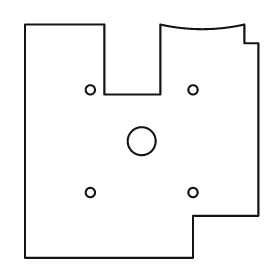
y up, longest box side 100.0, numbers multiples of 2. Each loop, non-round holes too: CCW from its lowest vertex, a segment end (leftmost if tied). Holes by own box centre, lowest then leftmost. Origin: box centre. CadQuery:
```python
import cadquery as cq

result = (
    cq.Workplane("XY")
    .moveTo(-50.0, -50.0)
    .lineTo(22.0, -50.0)
    .lineTo(22.0, -32.0)
    .lineTo(50.0, -32.0)
    .lineTo(50.0, 42.0)
    .lineTo(44.0, 42.0)
    .lineTo(44.0, 50.0)
    .threePointArc((26.0, 48.0), (8.0, 50.0))
    .lineTo(8.0, 20.0)
    .lineTo(-16.0, 20.0)
    .lineTo(-16.0, 50.0)
    .lineTo(-50.0, 50.0)
    .close()
    .moveTo(-22.0, -22.0)
    .circle(2.0)
    .moveTo(22.0, -22.0)
    .circle(2.0)
    .moveTo(0.0, 0.0)
    .circle(6.0)
    .moveTo(-22.0, 22.0)
    .circle(2.0)
    .moveTo(22.0, 22.0)
    .circle(2.0)
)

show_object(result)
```